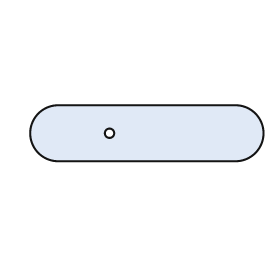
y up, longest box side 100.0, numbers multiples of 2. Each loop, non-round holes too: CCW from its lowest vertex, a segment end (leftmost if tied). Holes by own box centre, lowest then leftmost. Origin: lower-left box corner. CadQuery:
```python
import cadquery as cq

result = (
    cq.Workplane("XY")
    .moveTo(12.0, 0.0)
    .lineTo(88.0, 0.0)
    .threePointArc((100.0, 12.0), (88.0, 24.0))
    .lineTo(12.0, 24.0)
    .threePointArc((0.0, 12.0), (12.0, 0.0))
    .close()
    .moveTo(34.0, 12.0)
    .circle(2.0)
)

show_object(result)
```